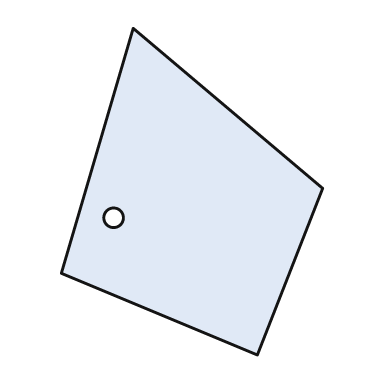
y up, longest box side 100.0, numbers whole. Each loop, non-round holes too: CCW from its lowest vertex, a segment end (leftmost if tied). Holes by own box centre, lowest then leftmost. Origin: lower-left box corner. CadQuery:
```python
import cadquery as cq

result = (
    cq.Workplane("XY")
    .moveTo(60.0, 0.0)
    .lineTo(80.0, 51.0)
    .lineTo(22.0, 100.0)
    .lineTo(0.0, 25.0)
    .close()
    .moveTo(16.0, 42.0)
    .circle(3.0)
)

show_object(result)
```